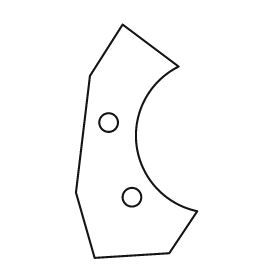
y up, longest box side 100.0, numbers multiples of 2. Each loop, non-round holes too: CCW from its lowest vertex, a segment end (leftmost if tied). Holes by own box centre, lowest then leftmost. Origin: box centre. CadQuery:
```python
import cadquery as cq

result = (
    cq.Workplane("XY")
    .moveTo(-18.0, -50.0)
    .lineTo(14.0, -48.0)
    .lineTo(26.0, -30.0)
    .threePointArc((0.0, -2.0), (18.0, 32.0))
    .lineTo(-6.0, 50.0)
    .lineTo(-20.0, 28.0)
    .lineTo(-26.0, -22.0)
    .close()
    .moveTo(-2.0, -24.0)
    .circle(4.0)
    .moveTo(-12.0, 8.0)
    .circle(4.0)
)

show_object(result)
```